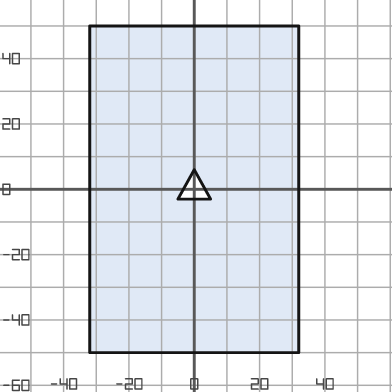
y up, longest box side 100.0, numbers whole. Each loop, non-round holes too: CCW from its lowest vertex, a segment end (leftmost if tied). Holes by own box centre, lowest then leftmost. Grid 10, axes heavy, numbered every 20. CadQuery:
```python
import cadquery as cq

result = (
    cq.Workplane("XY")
    .moveTo(-32.0, -50.0)
    .lineTo(32.0, -50.0)
    .lineTo(32.0, 50.0)
    .lineTo(-32.0, 50.0)
    .close()
    .moveTo(-5.0, -3.0)
    .lineTo(5.0, -3.0)
    .lineTo(0.0, 6.0)
    .close()
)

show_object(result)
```